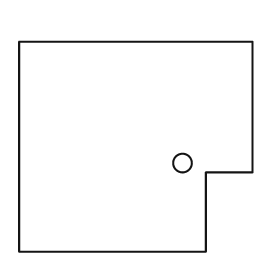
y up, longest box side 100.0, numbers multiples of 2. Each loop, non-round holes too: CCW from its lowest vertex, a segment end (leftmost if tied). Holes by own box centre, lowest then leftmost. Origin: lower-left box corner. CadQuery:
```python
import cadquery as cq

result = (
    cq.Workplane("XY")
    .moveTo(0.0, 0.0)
    .lineTo(80.0, 0.0)
    .lineTo(80.0, 34.0)
    .lineTo(100.0, 34.0)
    .lineTo(100.0, 90.0)
    .lineTo(0.0, 90.0)
    .close()
    .moveTo(70.0, 38.0)
    .circle(4.0)
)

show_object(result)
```